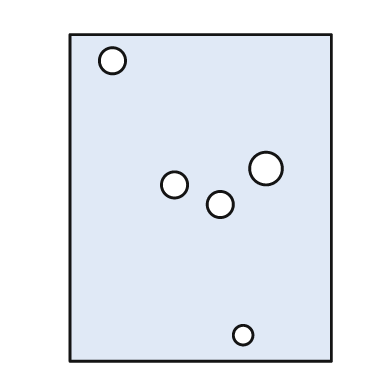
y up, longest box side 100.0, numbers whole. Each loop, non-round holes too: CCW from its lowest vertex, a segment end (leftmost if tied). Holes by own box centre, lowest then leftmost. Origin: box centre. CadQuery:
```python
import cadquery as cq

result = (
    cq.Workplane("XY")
    .moveTo(-40.0, -50.0)
    .lineTo(40.0, -50.0)
    .lineTo(40.0, 50.0)
    .lineTo(-40.0, 50.0)
    .close()
    .moveTo(13.0, -42.0)
    .circle(3.0)
    .moveTo(6.0, -2.0)
    .circle(4.0)
    .moveTo(-8.0, 4.0)
    .circle(4.0)
    .moveTo(20.0, 9.0)
    .circle(5.0)
    .moveTo(-27.0, 42.0)
    .circle(4.0)
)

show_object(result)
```